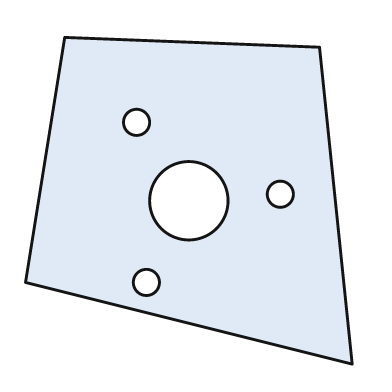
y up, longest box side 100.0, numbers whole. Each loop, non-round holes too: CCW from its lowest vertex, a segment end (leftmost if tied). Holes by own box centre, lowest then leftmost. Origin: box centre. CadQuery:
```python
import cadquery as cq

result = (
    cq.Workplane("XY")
    .moveTo(50.0, -50.0)
    .lineTo(40.0, 47.0)
    .lineTo(-38.0, 50.0)
    .lineTo(-50.0, -25.0)
    .close()
    .moveTo(-13.0, -25.0)
    .circle(4.0)
    .moveTo(0.0, 0.0)
    .circle(12.0)
    .moveTo(28.0, 2.0)
    .circle(4.0)
    .moveTo(-16.0, 24.0)
    .circle(4.0)
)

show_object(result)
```